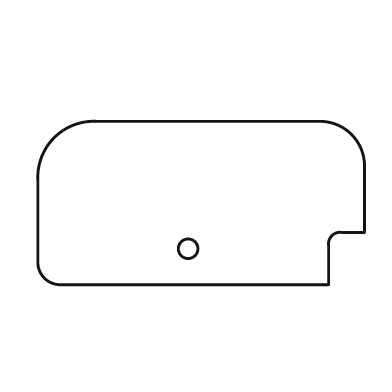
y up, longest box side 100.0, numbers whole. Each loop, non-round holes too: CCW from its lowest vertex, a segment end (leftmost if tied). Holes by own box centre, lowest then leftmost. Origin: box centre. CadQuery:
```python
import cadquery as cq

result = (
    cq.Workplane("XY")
    .moveTo(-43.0, -25.0)
    .lineTo(39.0, -25.0)
    .lineTo(39.0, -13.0)
    .threePointArc((40.0, -10.0), (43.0, -9.0))
    .lineTo(50.0, -9.0)
    .lineTo(50.0, 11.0)
    .threePointArc((46.0, 21.0), (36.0, 25.0))
    .lineTo(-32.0, 25.0)
    .threePointArc((-45.0, 20.0), (-50.0, 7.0))
    .lineTo(-50.0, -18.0)
    .threePointArc((-48.0, -23.0), (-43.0, -25.0))
    .close()
    .moveTo(-4.0, -14.0)
    .circle(3.0)
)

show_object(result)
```